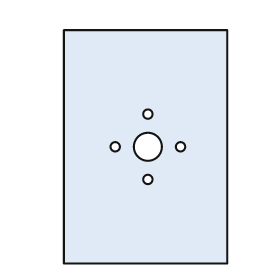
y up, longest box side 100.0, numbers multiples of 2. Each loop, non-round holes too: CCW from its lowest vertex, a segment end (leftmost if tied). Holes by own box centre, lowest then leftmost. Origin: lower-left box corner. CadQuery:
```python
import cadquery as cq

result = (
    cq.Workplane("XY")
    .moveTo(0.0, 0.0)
    .lineTo(70.0, 0.0)
    .lineTo(70.0, 100.0)
    .lineTo(0.0, 100.0)
    .close()
    .moveTo(36.0, 36.0)
    .circle(2.0)
    .moveTo(22.0, 50.0)
    .circle(2.0)
    .moveTo(36.0, 50.0)
    .circle(6.0)
    .moveTo(50.0, 50.0)
    .circle(2.0)
    .moveTo(36.0, 64.0)
    .circle(2.0)
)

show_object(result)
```